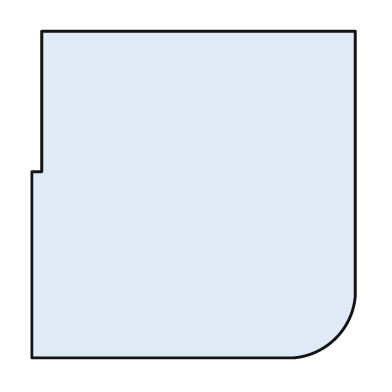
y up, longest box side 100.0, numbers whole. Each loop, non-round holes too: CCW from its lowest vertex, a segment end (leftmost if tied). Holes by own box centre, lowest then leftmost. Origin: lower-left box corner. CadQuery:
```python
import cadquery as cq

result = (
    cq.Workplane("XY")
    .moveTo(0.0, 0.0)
    .lineTo(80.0, 0.0)
    .threePointArc((93.0, 6.0), (99.0, 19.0))
    .lineTo(99.0, 100.0)
    .lineTo(3.0, 100.0)
    .lineTo(3.0, 57.0)
    .lineTo(0.0, 57.0)
    .close()
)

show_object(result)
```